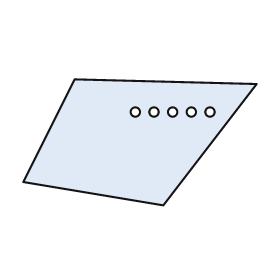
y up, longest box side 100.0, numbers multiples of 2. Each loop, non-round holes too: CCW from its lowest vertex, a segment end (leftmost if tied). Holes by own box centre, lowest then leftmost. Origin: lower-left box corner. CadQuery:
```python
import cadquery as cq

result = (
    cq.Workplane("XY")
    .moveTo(60.0, 0.0)
    .lineTo(100.0, 52.0)
    .lineTo(22.0, 54.0)
    .lineTo(0.0, 10.0)
    .close()
    .moveTo(48.0, 40.0)
    .circle(2.0)
    .moveTo(56.0, 40.0)
    .circle(2.0)
    .moveTo(64.0, 40.0)
    .circle(2.0)
    .moveTo(72.0, 40.0)
    .circle(2.0)
    .moveTo(80.0, 40.0)
    .circle(2.0)
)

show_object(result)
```